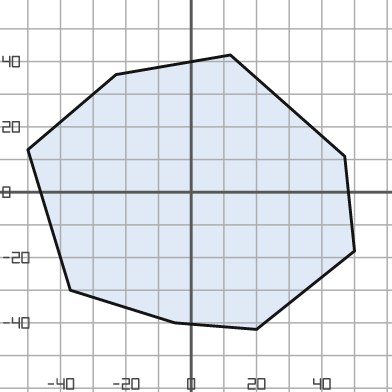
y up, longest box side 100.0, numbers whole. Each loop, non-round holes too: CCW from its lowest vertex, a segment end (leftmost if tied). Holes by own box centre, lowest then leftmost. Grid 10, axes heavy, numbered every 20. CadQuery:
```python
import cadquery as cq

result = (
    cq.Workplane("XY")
    .moveTo(20.0, -42.0)
    .lineTo(50.0, -18.0)
    .lineTo(47.0, 11.0)
    .lineTo(12.0, 42.0)
    .lineTo(-23.0, 36.0)
    .lineTo(-50.0, 13.0)
    .lineTo(-37.0, -30.0)
    .lineTo(-5.0, -40.0)
    .close()
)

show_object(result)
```